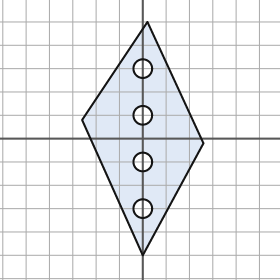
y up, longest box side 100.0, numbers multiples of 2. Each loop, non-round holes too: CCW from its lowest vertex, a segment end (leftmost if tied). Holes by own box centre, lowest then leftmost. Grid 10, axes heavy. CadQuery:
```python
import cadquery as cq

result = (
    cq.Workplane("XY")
    .moveTo(0.0, -50.0)
    .lineTo(26.0, -2.0)
    .lineTo(2.0, 50.0)
    .lineTo(-26.0, 8.0)
    .close()
    .moveTo(0.0, -30.0)
    .circle(4.0)
    .moveTo(0.0, -10.0)
    .circle(4.0)
    .moveTo(0.0, 10.0)
    .circle(4.0)
    .moveTo(0.0, 30.0)
    .circle(4.0)
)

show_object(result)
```